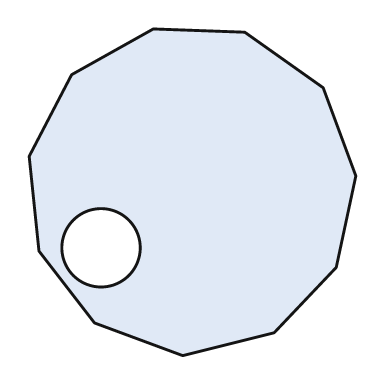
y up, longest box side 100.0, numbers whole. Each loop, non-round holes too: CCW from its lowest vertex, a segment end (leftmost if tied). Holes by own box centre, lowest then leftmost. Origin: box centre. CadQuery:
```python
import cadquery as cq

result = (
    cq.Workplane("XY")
    .moveTo(-3.0, -50.0)
    .lineTo(25.0, -43.0)
    .lineTo(44.0, -23.0)
    .lineTo(50.0, 5.0)
    .lineTo(40.0, 32.0)
    .lineTo(16.0, 49.0)
    .lineTo(-12.0, 50.0)
    .lineTo(-37.0, 36.0)
    .lineTo(-50.0, 11.0)
    .lineTo(-47.0, -18.0)
    .lineTo(-30.0, -40.0)
    .close()
    .moveTo(-28.0, -17.0)
    .circle(12.0)
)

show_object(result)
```